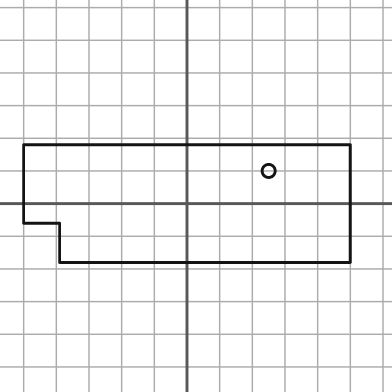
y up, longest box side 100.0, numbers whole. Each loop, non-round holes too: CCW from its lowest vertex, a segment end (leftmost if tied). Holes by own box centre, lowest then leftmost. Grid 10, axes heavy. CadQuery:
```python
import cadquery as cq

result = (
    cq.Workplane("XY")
    .moveTo(-39.0, -18.0)
    .lineTo(50.0, -18.0)
    .lineTo(50.0, 18.0)
    .lineTo(-50.0, 18.0)
    .lineTo(-50.0, -6.0)
    .lineTo(-39.0, -6.0)
    .close()
    .moveTo(25.0, 10.0)
    .circle(2.0)
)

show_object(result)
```